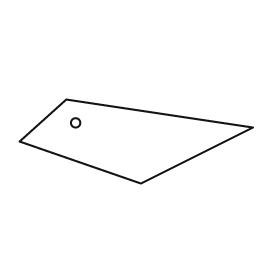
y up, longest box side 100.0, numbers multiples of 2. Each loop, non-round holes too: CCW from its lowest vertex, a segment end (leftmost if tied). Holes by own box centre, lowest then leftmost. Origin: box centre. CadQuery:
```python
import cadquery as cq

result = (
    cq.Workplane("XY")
    .moveTo(2.0, -18.0)
    .lineTo(50.0, 6.0)
    .lineTo(-30.0, 18.0)
    .lineTo(-50.0, 0.0)
    .close()
    .moveTo(-26.0, 8.0)
    .circle(2.0)
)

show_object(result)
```